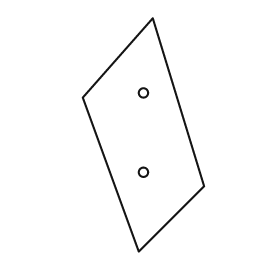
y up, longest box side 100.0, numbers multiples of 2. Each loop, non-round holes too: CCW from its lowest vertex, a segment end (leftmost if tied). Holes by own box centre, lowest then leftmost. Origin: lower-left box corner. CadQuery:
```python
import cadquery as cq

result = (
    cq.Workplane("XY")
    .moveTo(24.0, 0.0)
    .lineTo(52.0, 28.0)
    .lineTo(30.0, 100.0)
    .lineTo(0.0, 66.0)
    .close()
    .moveTo(26.0, 34.0)
    .circle(2.0)
    .moveTo(26.0, 68.0)
    .circle(2.0)
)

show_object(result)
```